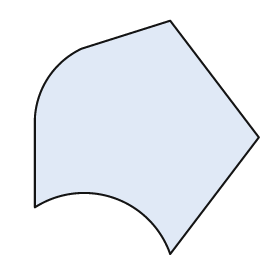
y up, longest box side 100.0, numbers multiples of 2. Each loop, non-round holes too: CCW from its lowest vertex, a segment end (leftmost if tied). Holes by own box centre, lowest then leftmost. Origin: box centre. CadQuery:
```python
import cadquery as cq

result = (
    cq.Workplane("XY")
    .moveTo(10.0, -50.0)
    .lineTo(48.0, 0.0)
    .lineTo(10.0, 50.0)
    .lineTo(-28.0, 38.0)
    .threePointArc((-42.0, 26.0), (-48.0, 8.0))
    .lineTo(-48.0, -30.0)
    .threePointArc((-14.0, -26.0), (10.0, -50.0))
    .close()
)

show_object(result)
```